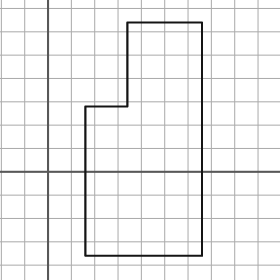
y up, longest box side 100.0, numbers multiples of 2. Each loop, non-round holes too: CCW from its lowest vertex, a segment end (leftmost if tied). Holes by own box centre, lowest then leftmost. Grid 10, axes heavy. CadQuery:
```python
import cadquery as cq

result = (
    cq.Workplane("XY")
    .moveTo(16.0, -36.0)
    .lineTo(66.0, -36.0)
    .lineTo(66.0, 64.0)
    .lineTo(34.0, 64.0)
    .lineTo(34.0, 28.0)
    .lineTo(16.0, 28.0)
    .close()
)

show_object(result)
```